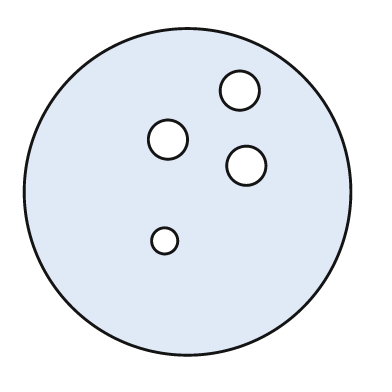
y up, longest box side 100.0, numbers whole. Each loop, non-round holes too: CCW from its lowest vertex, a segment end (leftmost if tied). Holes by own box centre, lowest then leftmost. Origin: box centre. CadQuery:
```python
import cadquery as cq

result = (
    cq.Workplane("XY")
    .moveTo(0.0, 0.0)
    .circle(50.0)
    .moveTo(-7.0, -15.0)
    .circle(4.0)
    .moveTo(18.0, 8.0)
    .circle(6.0)
    .moveTo(-6.0, 16.0)
    .circle(6.0)
    .moveTo(16.0, 31.0)
    .circle(6.0)
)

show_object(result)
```